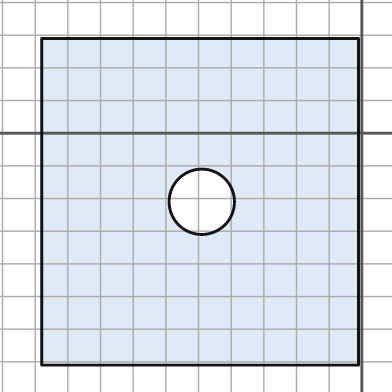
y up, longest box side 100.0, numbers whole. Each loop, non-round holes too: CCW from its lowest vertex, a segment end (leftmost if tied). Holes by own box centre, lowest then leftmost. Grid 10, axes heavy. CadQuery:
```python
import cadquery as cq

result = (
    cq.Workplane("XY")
    .moveTo(-98.0, -71.0)
    .lineTo(-1.0, -71.0)
    .lineTo(-1.0, 29.0)
    .lineTo(-98.0, 29.0)
    .close()
    .moveTo(-49.0, -21.0)
    .circle(10.0)
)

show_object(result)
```